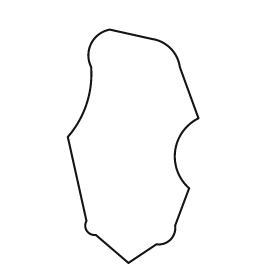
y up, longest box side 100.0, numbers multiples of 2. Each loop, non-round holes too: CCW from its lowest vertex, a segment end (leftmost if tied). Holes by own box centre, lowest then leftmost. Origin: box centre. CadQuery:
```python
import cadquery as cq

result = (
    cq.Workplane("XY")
    .moveTo(-2.0, -50.0)
    .lineTo(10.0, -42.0)
    .threePointArc((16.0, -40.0), (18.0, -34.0))
    .lineTo(24.0, -18.0)
    .threePointArc((18.0, -2.0), (28.0, 12.0))
    .lineTo(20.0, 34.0)
    .threePointArc((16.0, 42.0), (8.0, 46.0))
    .lineTo(-10.0, 50.0)
    .threePointArc((-18.0, 44.0), (-18.0, 34.0))
    .threePointArc((-20.0, 18.0), (-28.0, 4.0))
    .lineTo(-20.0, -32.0)
    .threePointArc((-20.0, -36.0), (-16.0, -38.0))
    .close()
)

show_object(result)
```